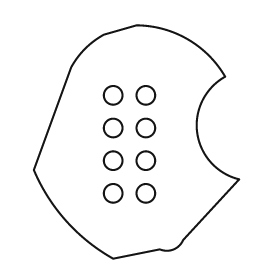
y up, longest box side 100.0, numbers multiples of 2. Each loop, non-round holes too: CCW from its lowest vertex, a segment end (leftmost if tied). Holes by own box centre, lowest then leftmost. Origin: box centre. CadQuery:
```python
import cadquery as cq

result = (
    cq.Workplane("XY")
    .moveTo(-10.0, -50.0)
    .lineTo(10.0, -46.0)
    .threePointArc((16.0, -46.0), (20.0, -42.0))
    .lineTo(44.0, -16.0)
    .threePointArc((26.0, 4.0), (38.0, 28.0))
    .threePointArc((22.0, 44.0), (0.0, 50.0))
    .lineTo(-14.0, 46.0)
    .threePointArc((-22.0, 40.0), (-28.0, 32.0))
    .lineTo(-44.0, -12.0)
    .threePointArc((-30.0, -34.0), (-10.0, -50.0))
    .close()
    .moveTo(-10.0, -22.0)
    .circle(4.0)
    .moveTo(4.0, -22.0)
    .circle(4.0)
    .moveTo(-10.0, -8.0)
    .circle(4.0)
    .moveTo(4.0, -8.0)
    .circle(4.0)
    .moveTo(-10.0, 6.0)
    .circle(4.0)
    .moveTo(4.0, 6.0)
    .circle(4.0)
    .moveTo(-10.0, 20.0)
    .circle(4.0)
    .moveTo(4.0, 20.0)
    .circle(4.0)
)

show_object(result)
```